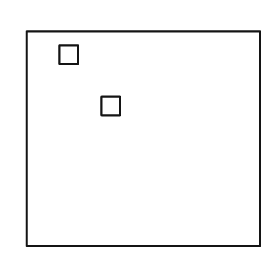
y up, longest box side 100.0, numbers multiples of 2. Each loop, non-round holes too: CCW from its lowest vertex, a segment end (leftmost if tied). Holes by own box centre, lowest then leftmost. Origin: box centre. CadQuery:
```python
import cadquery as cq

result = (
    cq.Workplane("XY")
    .moveTo(-50.0, -46.0)
    .lineTo(50.0, -46.0)
    .lineTo(50.0, 46.0)
    .lineTo(-50.0, 46.0)
    .close()
    .moveTo(-18.0, 10.0)
    .lineTo(-10.0, 10.0)
    .lineTo(-10.0, 18.0)
    .lineTo(-18.0, 18.0)
    .close()
    .moveTo(-36.0, 32.0)
    .lineTo(-28.0, 32.0)
    .lineTo(-28.0, 40.0)
    .lineTo(-36.0, 40.0)
    .close()
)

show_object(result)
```